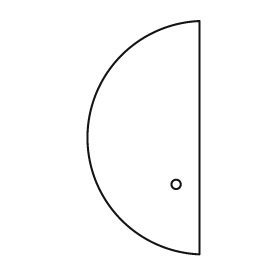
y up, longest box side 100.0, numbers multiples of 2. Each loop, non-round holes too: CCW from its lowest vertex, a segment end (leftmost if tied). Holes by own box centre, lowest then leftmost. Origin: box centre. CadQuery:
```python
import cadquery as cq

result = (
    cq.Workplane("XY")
    .moveTo(24.0, -50.0)
    .lineTo(24.0, 50.0)
    .threePointArc((-24.0, 0.0), (24.0, -50.0))
    .close()
    .moveTo(14.0, -20.0)
    .circle(2.0)
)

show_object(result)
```